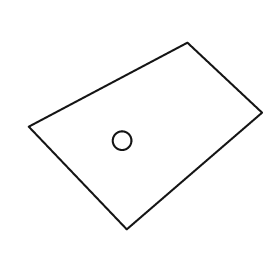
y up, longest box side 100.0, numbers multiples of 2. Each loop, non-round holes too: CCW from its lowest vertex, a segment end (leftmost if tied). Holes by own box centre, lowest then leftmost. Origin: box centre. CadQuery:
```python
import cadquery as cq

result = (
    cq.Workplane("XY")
    .moveTo(-8.0, -40.0)
    .lineTo(50.0, 10.0)
    .lineTo(18.0, 40.0)
    .lineTo(-50.0, 4.0)
    .close()
    .moveTo(-10.0, -2.0)
    .circle(4.0)
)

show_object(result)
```